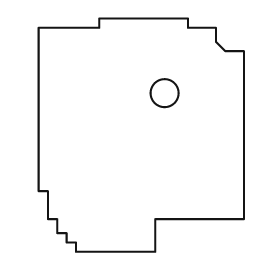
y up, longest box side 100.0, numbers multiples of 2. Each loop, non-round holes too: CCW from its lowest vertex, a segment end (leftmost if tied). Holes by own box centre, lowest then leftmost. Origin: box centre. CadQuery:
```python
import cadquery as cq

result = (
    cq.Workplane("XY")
    .moveTo(-28.0, -50.0)
    .lineTo(6.0, -50.0)
    .lineTo(6.0, -36.0)
    .lineTo(44.0, -36.0)
    .lineTo(44.0, 36.0)
    .lineTo(36.0, 36.0)
    .lineTo(32.0, 40.0)
    .lineTo(32.0, 46.0)
    .lineTo(20.0, 46.0)
    .lineTo(20.0, 50.0)
    .lineTo(-18.0, 50.0)
    .lineTo(-18.0, 46.0)
    .lineTo(-44.0, 46.0)
    .lineTo(-44.0, -24.0)
    .lineTo(-40.0, -24.0)
    .lineTo(-40.0, -36.0)
    .lineTo(-36.0, -36.0)
    .lineTo(-36.0, -42.0)
    .lineTo(-32.0, -42.0)
    .lineTo(-32.0, -46.0)
    .lineTo(-28.0, -46.0)
    .close()
    .moveTo(10.0, 18.0)
    .circle(6.0)
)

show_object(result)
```